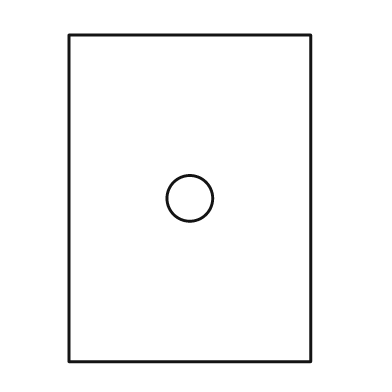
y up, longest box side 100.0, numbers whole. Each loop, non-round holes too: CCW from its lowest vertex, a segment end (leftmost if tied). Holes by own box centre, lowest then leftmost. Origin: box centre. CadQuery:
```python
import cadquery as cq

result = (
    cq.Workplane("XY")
    .moveTo(-37.0, -50.0)
    .lineTo(37.0, -50.0)
    .lineTo(37.0, 50.0)
    .lineTo(-37.0, 50.0)
    .close()
    .moveTo(0.0, 0.0)
    .circle(7.0)
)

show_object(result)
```